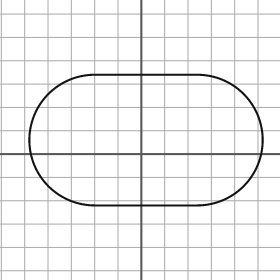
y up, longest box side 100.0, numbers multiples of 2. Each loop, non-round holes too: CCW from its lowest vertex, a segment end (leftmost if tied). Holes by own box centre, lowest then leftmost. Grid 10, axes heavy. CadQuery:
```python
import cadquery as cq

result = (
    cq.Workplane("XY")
    .moveTo(-20.0, -22.0)
    .lineTo(24.0, -22.0)
    .threePointArc((52.0, 6.0), (24.0, 34.0))
    .lineTo(-20.0, 34.0)
    .threePointArc((-48.0, 6.0), (-20.0, -22.0))
    .close()
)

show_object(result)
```